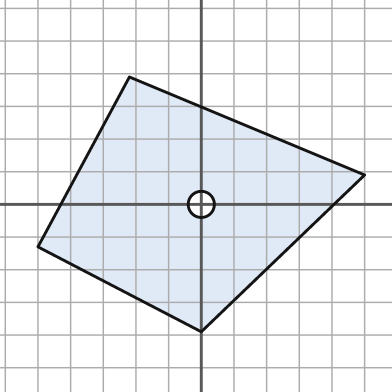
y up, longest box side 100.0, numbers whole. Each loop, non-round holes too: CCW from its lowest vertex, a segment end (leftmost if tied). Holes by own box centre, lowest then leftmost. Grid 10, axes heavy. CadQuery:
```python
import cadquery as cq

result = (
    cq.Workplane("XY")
    .moveTo(0.0, -39.0)
    .lineTo(50.0, 9.0)
    .lineTo(-22.0, 39.0)
    .lineTo(-50.0, -13.0)
    .close()
    .moveTo(0.0, 0.0)
    .circle(4.0)
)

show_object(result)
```